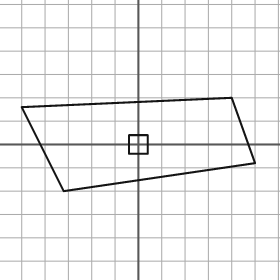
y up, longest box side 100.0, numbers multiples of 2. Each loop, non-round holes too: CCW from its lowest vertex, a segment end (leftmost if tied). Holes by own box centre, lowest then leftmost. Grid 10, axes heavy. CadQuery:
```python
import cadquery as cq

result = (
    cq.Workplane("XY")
    .moveTo(-32.0, -20.0)
    .lineTo(50.0, -8.0)
    .lineTo(40.0, 20.0)
    .lineTo(-50.0, 16.0)
    .close()
    .moveTo(-4.0, -4.0)
    .lineTo(4.0, -4.0)
    .lineTo(4.0, 4.0)
    .lineTo(-4.0, 4.0)
    .close()
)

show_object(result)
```